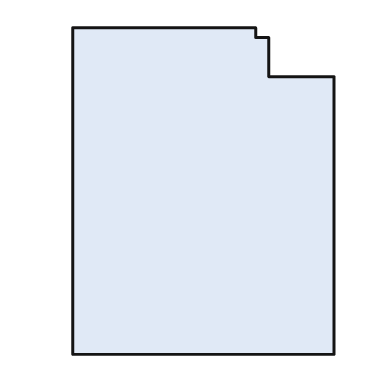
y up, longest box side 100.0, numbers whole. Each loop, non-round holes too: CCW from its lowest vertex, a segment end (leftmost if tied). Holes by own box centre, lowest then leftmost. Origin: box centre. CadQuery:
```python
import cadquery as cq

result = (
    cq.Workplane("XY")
    .moveTo(-40.0, -50.0)
    .lineTo(40.0, -50.0)
    .lineTo(40.0, 35.0)
    .lineTo(20.0, 35.0)
    .lineTo(20.0, 47.0)
    .lineTo(16.0, 47.0)
    .lineTo(16.0, 50.0)
    .lineTo(-40.0, 50.0)
    .close()
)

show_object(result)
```